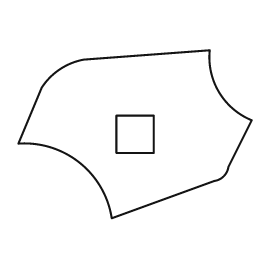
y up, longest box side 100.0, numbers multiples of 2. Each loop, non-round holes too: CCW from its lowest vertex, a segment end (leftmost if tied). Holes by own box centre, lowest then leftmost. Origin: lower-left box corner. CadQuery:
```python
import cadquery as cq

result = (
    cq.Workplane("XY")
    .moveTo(40.0, 0.0)
    .lineTo(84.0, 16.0)
    .threePointArc((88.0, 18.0), (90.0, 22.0))
    .lineTo(100.0, 42.0)
    .threePointArc((86.0, 54.0), (82.0, 72.0))
    .lineTo(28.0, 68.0)
    .threePointArc((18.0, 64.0), (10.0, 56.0))
    .lineTo(0.0, 32.0)
    .threePointArc((26.0, 24.0), (40.0, 0.0))
    .close()
    .moveTo(42.0, 28.0)
    .lineTo(58.0, 28.0)
    .lineTo(58.0, 44.0)
    .lineTo(42.0, 44.0)
    .close()
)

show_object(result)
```